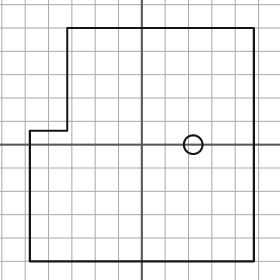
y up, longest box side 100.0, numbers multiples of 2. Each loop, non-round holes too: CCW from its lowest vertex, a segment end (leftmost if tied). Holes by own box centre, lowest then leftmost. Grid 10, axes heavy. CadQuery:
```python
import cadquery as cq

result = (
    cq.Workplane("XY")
    .moveTo(-48.0, -50.0)
    .lineTo(48.0, -50.0)
    .lineTo(48.0, 50.0)
    .lineTo(-32.0, 50.0)
    .lineTo(-32.0, 6.0)
    .lineTo(-48.0, 6.0)
    .close()
    .moveTo(22.0, 0.0)
    .circle(4.0)
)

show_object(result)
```